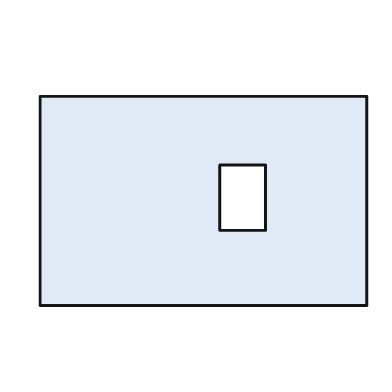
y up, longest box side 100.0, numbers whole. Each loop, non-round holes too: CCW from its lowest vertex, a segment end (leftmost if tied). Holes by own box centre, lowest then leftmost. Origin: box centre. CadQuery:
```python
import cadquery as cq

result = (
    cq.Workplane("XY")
    .moveTo(-50.0, -32.0)
    .lineTo(50.0, -32.0)
    .lineTo(50.0, 32.0)
    .lineTo(-50.0, 32.0)
    .close()
    .moveTo(5.0, -9.0)
    .lineTo(19.0, -9.0)
    .lineTo(19.0, 11.0)
    .lineTo(5.0, 11.0)
    .close()
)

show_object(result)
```